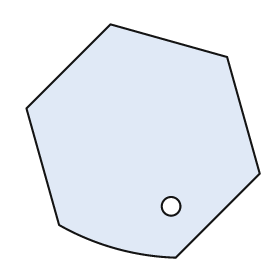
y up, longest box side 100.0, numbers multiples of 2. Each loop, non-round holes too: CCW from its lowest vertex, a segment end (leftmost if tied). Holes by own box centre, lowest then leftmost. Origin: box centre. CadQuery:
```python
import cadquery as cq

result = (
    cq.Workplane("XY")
    .moveTo(14.0, -50.0)
    .lineTo(50.0, -14.0)
    .lineTo(36.0, 36.0)
    .lineTo(-14.0, 50.0)
    .lineTo(-50.0, 14.0)
    .lineTo(-36.0, -36.0)
    .threePointArc((-12.0, -46.0), (14.0, -50.0))
    .close()
    .moveTo(12.0, -28.0)
    .circle(4.0)
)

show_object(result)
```